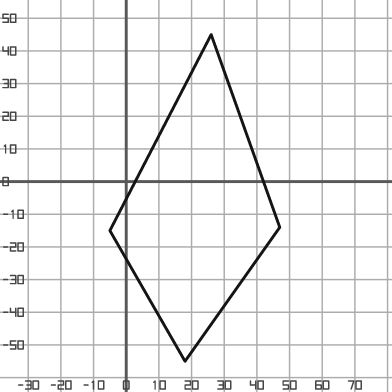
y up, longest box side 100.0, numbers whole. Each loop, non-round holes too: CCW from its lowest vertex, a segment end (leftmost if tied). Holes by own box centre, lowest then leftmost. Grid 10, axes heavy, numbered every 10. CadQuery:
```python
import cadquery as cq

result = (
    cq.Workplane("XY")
    .moveTo(18.0, -55.0)
    .lineTo(47.0, -14.0)
    .lineTo(26.0, 45.0)
    .lineTo(-5.0, -15.0)
    .close()
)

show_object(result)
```